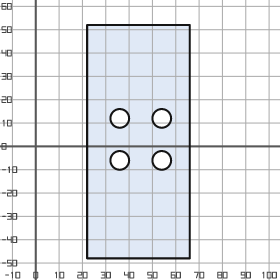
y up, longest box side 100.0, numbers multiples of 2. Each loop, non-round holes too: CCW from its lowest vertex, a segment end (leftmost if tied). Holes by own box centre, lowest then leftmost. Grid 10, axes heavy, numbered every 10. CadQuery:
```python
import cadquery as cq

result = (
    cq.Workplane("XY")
    .moveTo(22.0, -48.0)
    .lineTo(66.0, -48.0)
    .lineTo(66.0, 52.0)
    .lineTo(22.0, 52.0)
    .close()
    .moveTo(36.0, -6.0)
    .circle(4.0)
    .moveTo(54.0, -6.0)
    .circle(4.0)
    .moveTo(36.0, 12.0)
    .circle(4.0)
    .moveTo(54.0, 12.0)
    .circle(4.0)
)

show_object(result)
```